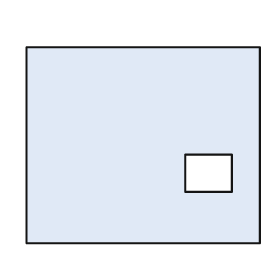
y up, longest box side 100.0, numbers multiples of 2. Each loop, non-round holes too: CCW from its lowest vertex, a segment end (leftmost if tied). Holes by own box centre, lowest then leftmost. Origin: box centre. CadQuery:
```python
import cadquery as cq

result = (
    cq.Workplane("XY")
    .moveTo(-50.0, -42.0)
    .lineTo(50.0, -42.0)
    .lineTo(50.0, 42.0)
    .lineTo(-50.0, 42.0)
    .close()
    .moveTo(18.0, -20.0)
    .lineTo(38.0, -20.0)
    .lineTo(38.0, -4.0)
    .lineTo(18.0, -4.0)
    .close()
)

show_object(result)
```